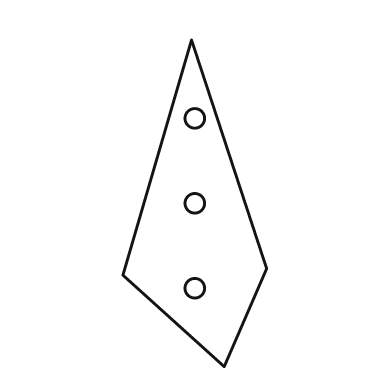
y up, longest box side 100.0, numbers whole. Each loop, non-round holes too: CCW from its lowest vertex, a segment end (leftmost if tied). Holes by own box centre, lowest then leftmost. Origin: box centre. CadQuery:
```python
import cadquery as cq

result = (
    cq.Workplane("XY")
    .moveTo(9.0, -50.0)
    .lineTo(22.0, -20.0)
    .lineTo(-1.0, 50.0)
    .lineTo(-22.0, -22.0)
    .close()
    .moveTo(0.0, -26.0)
    .circle(3.0)
    .moveTo(0.0, 0.0)
    .circle(3.0)
    .moveTo(0.0, 26.0)
    .circle(3.0)
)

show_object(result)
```